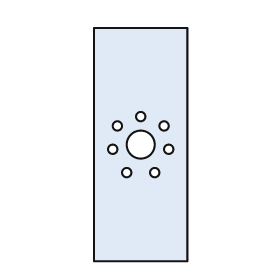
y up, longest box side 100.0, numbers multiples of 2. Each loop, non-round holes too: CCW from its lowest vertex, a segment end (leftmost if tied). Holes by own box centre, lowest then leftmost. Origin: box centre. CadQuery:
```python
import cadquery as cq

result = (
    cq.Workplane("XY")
    .moveTo(-20.0, -50.0)
    .lineTo(20.0, -50.0)
    .lineTo(20.0, 50.0)
    .lineTo(-20.0, 50.0)
    .close()
    .moveTo(-6.0, -12.0)
    .circle(2.0)
    .moveTo(6.0, -12.0)
    .circle(2.0)
    .moveTo(-12.0, -2.0)
    .circle(2.0)
    .moveTo(12.0, -2.0)
    .circle(2.0)
    .moveTo(0.0, 0.0)
    .circle(6.0)
    .moveTo(-10.0, 8.0)
    .circle(2.0)
    .moveTo(10.0, 8.0)
    .circle(2.0)
    .moveTo(0.0, 12.0)
    .circle(2.0)
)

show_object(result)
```